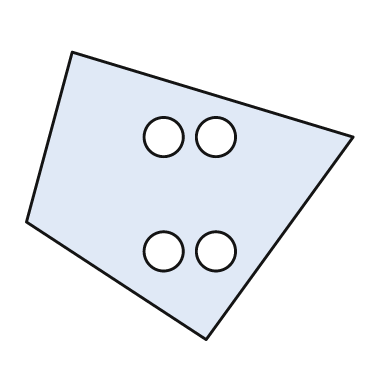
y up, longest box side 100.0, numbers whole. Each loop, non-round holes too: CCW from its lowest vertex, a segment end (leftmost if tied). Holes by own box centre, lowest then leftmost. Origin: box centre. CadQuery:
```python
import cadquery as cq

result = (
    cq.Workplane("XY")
    .moveTo(5.0, -44.0)
    .lineTo(50.0, 18.0)
    .lineTo(-36.0, 44.0)
    .lineTo(-50.0, -8.0)
    .close()
    .moveTo(-8.0, -17.0)
    .circle(6.0)
    .moveTo(8.0, -17.0)
    .circle(6.0)
    .moveTo(-8.0, 18.0)
    .circle(6.0)
    .moveTo(8.0, 18.0)
    .circle(6.0)
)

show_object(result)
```